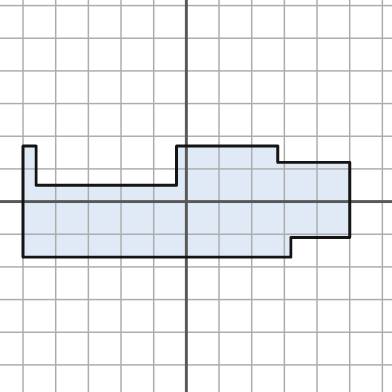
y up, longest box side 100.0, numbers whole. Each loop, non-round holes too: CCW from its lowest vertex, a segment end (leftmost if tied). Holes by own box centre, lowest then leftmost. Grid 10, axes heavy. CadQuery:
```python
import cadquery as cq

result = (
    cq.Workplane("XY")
    .moveTo(-50.0, -17.0)
    .lineTo(32.0, -17.0)
    .lineTo(32.0, -11.0)
    .lineTo(50.0, -11.0)
    .lineTo(50.0, 12.0)
    .lineTo(28.0, 12.0)
    .lineTo(28.0, 17.0)
    .lineTo(-3.0, 17.0)
    .lineTo(-3.0, 5.0)
    .lineTo(-46.0, 5.0)
    .lineTo(-46.0, 17.0)
    .lineTo(-50.0, 17.0)
    .close()
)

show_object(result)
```